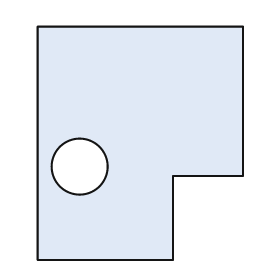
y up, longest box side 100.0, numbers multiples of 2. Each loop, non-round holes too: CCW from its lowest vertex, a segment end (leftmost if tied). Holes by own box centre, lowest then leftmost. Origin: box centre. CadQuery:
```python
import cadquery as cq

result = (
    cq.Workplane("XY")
    .moveTo(-44.0, -50.0)
    .lineTo(14.0, -50.0)
    .lineTo(14.0, -14.0)
    .lineTo(44.0, -14.0)
    .lineTo(44.0, 50.0)
    .lineTo(-44.0, 50.0)
    .close()
    .moveTo(-26.0, -10.0)
    .circle(12.0)
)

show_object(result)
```